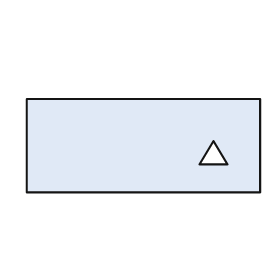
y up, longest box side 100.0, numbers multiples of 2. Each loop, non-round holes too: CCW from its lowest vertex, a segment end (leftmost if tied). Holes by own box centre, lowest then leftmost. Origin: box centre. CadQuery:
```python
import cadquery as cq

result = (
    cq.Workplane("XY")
    .moveTo(-50.0, -20.0)
    .lineTo(50.0, -20.0)
    .lineTo(50.0, 20.0)
    .lineTo(-50.0, 20.0)
    .close()
    .moveTo(24.0, -8.0)
    .lineTo(36.0, -8.0)
    .lineTo(30.0, 2.0)
    .close()
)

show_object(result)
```